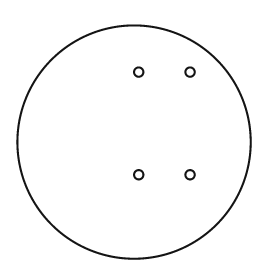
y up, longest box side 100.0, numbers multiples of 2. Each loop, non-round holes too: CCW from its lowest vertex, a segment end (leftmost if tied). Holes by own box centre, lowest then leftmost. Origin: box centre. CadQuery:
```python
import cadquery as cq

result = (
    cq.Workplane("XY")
    .moveTo(0.0, 0.0)
    .circle(50.0)
    .moveTo(2.0, -14.0)
    .circle(2.0)
    .moveTo(24.0, -14.0)
    .circle(2.0)
    .moveTo(2.0, 30.0)
    .circle(2.0)
    .moveTo(24.0, 30.0)
    .circle(2.0)
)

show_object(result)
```